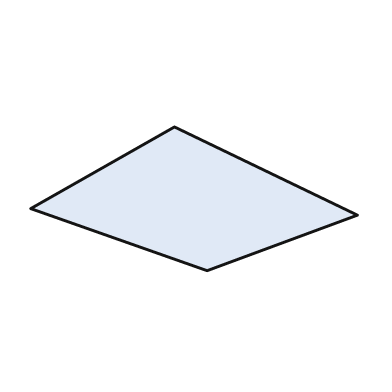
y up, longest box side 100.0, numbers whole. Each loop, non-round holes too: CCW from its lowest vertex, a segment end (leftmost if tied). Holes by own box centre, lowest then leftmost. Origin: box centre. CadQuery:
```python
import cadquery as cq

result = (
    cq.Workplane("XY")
    .moveTo(4.0, -22.0)
    .lineTo(50.0, -5.0)
    .lineTo(-6.0, 22.0)
    .lineTo(-50.0, -3.0)
    .close()
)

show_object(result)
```